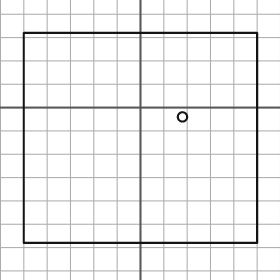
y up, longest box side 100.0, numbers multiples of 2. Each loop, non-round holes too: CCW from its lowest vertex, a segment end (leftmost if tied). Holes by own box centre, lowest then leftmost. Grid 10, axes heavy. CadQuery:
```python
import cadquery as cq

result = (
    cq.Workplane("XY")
    .moveTo(-50.0, -58.0)
    .lineTo(50.0, -58.0)
    .lineTo(50.0, 32.0)
    .lineTo(-50.0, 32.0)
    .close()
    .moveTo(18.0, -4.0)
    .circle(2.0)
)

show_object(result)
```